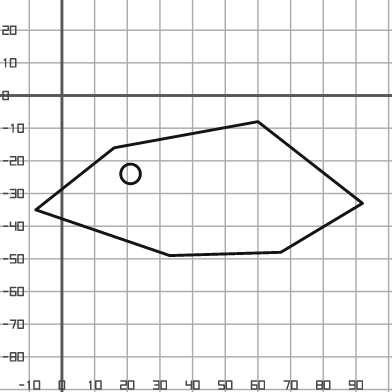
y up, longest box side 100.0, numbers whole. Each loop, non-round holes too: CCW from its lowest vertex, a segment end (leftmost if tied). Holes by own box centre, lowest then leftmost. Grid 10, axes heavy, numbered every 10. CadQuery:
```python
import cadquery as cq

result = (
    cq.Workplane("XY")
    .moveTo(33.0, -49.0)
    .lineTo(67.0, -48.0)
    .lineTo(92.0, -33.0)
    .lineTo(60.0, -8.0)
    .lineTo(16.0, -16.0)
    .lineTo(-8.0, -35.0)
    .close()
    .moveTo(21.0, -24.0)
    .circle(3.0)
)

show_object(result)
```